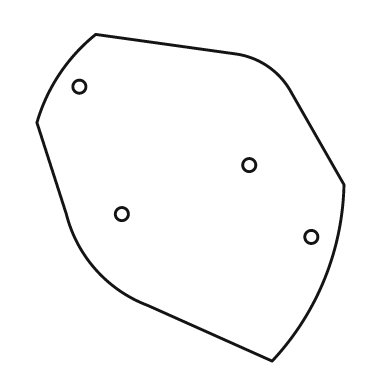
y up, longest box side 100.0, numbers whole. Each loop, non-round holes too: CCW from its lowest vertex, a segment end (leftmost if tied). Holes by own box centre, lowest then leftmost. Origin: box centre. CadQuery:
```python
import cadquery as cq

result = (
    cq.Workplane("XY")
    .moveTo(25.0, -50.0)
    .threePointArc((41.0, -25.0), (47.0, 4.0))
    .lineTo(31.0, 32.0)
    .threePointArc((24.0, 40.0), (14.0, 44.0))
    .lineTo(-29.0, 50.0)
    .threePointArc((-40.0, 38.0), (-47.0, 23.0))
    .lineTo(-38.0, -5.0)
    .threePointArc((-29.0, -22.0), (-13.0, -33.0))
    .close()
    .moveTo(37.0, -12.0)
    .circle(2.0)
    .moveTo(-21.0, -5.0)
    .circle(2.0)
    .moveTo(18.0, 10.0)
    .circle(2.0)
    .moveTo(-34.0, 34.0)
    .circle(2.0)
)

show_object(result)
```